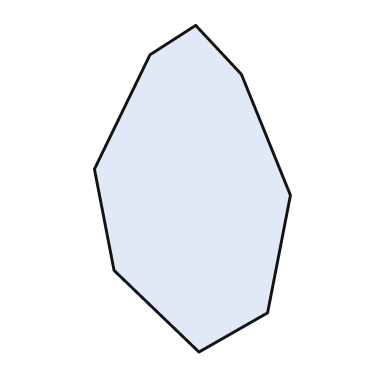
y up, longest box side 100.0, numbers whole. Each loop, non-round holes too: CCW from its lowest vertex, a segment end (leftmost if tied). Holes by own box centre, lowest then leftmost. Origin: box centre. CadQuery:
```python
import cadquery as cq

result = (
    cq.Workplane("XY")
    .moveTo(2.0, -50.0)
    .lineTo(23.0, -38.0)
    .lineTo(30.0, -2.0)
    .lineTo(15.0, 35.0)
    .lineTo(1.0, 50.0)
    .lineTo(-13.0, 41.0)
    .lineTo(-30.0, 6.0)
    .lineTo(-24.0, -25.0)
    .close()
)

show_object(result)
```